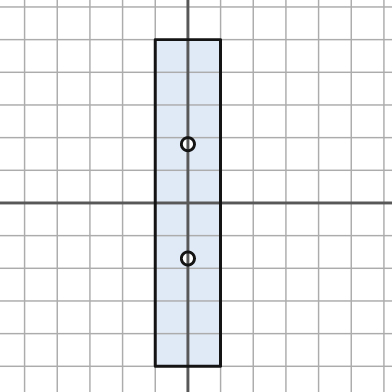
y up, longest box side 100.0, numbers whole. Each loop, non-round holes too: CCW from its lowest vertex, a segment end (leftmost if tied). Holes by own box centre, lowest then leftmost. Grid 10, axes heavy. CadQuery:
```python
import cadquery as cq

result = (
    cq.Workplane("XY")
    .moveTo(-10.0, -50.0)
    .lineTo(10.0, -50.0)
    .lineTo(10.0, 50.0)
    .lineTo(-10.0, 50.0)
    .close()
    .moveTo(0.0, -17.0)
    .circle(2.0)
    .moveTo(0.0, 18.0)
    .circle(2.0)
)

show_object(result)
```